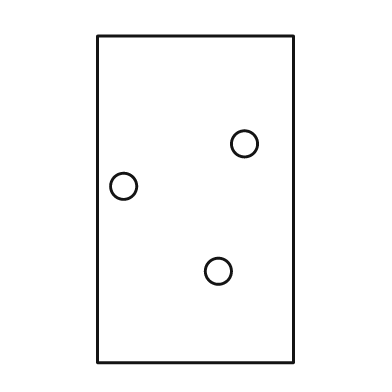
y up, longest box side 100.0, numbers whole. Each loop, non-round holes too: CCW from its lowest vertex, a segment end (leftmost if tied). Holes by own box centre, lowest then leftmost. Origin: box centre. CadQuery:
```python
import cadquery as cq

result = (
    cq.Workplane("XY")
    .moveTo(-30.0, -50.0)
    .lineTo(30.0, -50.0)
    .lineTo(30.0, 50.0)
    .lineTo(-30.0, 50.0)
    .close()
    .moveTo(7.0, -22.0)
    .circle(4.0)
    .moveTo(-22.0, 4.0)
    .circle(4.0)
    .moveTo(15.0, 17.0)
    .circle(4.0)
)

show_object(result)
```